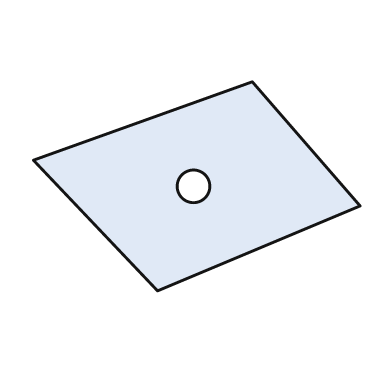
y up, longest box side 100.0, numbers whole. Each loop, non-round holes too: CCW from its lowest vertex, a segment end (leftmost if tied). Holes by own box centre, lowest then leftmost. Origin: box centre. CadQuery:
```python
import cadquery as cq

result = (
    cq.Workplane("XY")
    .moveTo(-12.0, -32.0)
    .lineTo(50.0, -6.0)
    .lineTo(17.0, 32.0)
    .lineTo(-50.0, 8.0)
    .close()
    .moveTo(-1.0, 0.0)
    .circle(5.0)
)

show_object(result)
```